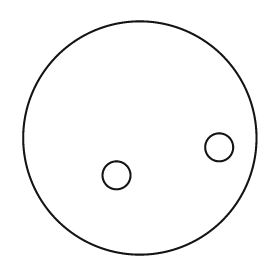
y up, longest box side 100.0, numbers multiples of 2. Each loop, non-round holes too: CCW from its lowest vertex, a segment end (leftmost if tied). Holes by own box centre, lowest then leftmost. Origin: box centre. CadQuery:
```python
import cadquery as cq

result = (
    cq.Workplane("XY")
    .moveTo(0.0, 0.0)
    .circle(50.0)
    .moveTo(-10.0, -16.0)
    .circle(6.0)
    .moveTo(34.0, -4.0)
    .circle(6.0)
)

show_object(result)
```